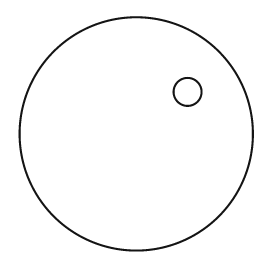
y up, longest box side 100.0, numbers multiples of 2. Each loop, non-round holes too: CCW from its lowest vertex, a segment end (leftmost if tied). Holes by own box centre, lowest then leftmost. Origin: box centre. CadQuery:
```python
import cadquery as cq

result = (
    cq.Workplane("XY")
    .moveTo(0.0, 0.0)
    .circle(50.0)
    .moveTo(22.0, 18.0)
    .circle(6.0)
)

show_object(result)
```